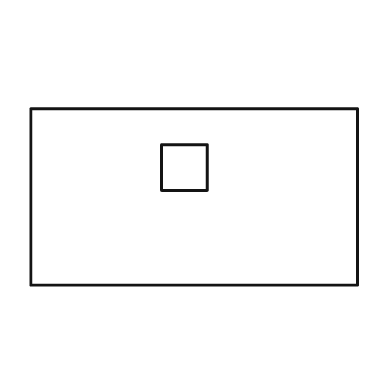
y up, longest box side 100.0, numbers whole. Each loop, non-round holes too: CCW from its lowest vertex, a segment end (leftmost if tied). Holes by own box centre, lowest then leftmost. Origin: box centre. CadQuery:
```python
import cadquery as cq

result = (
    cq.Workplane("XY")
    .moveTo(-50.0, -27.0)
    .lineTo(50.0, -27.0)
    .lineTo(50.0, 27.0)
    .lineTo(-50.0, 27.0)
    .close()
    .moveTo(-10.0, 2.0)
    .lineTo(4.0, 2.0)
    .lineTo(4.0, 16.0)
    .lineTo(-10.0, 16.0)
    .close()
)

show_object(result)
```